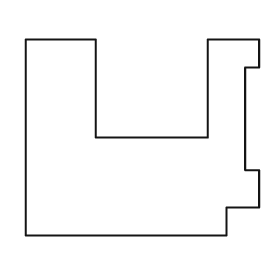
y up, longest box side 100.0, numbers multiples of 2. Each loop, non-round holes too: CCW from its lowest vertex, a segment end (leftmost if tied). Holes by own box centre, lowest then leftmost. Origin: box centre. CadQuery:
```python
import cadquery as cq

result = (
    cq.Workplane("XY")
    .moveTo(-50.0, -42.0)
    .lineTo(36.0, -42.0)
    .lineTo(36.0, -30.0)
    .lineTo(50.0, -30.0)
    .lineTo(50.0, -14.0)
    .lineTo(44.0, -14.0)
    .lineTo(44.0, 30.0)
    .lineTo(50.0, 30.0)
    .lineTo(50.0, 42.0)
    .lineTo(28.0, 42.0)
    .lineTo(28.0, 0.0)
    .lineTo(-20.0, 0.0)
    .lineTo(-20.0, 42.0)
    .lineTo(-50.0, 42.0)
    .close()
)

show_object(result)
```